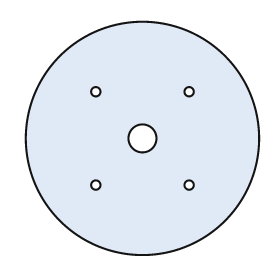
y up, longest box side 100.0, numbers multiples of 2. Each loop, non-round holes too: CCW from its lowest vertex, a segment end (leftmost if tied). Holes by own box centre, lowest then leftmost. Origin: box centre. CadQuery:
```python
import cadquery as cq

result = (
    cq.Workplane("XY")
    .moveTo(0.0, 0.0)
    .circle(50.0)
    .moveTo(-20.0, -20.0)
    .circle(2.0)
    .moveTo(20.0, -20.0)
    .circle(2.0)
    .moveTo(0.0, 0.0)
    .circle(6.0)
    .moveTo(-20.0, 20.0)
    .circle(2.0)
    .moveTo(20.0, 20.0)
    .circle(2.0)
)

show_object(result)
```